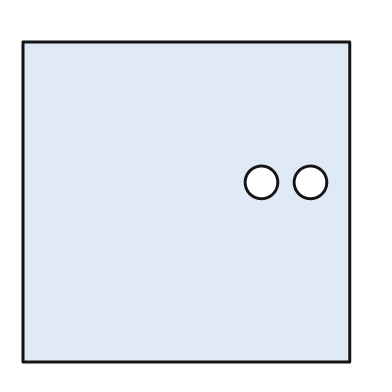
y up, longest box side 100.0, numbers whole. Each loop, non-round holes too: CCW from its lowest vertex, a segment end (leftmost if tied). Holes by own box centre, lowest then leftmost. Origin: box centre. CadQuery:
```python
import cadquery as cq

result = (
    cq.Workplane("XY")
    .moveTo(-50.0, -49.0)
    .lineTo(50.0, -49.0)
    .lineTo(50.0, 49.0)
    .lineTo(-50.0, 49.0)
    .close()
    .moveTo(23.0, 6.0)
    .circle(5.0)
    .moveTo(38.0, 6.0)
    .circle(5.0)
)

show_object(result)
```